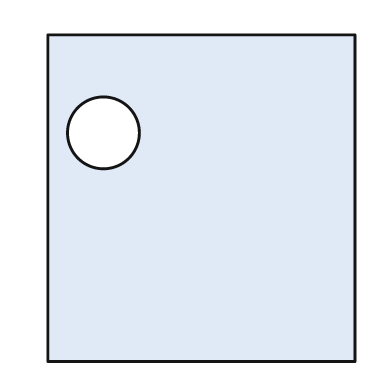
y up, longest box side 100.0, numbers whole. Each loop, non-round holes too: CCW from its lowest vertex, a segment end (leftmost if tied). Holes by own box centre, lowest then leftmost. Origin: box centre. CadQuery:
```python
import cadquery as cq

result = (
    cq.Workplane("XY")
    .moveTo(-47.0, -50.0)
    .lineTo(47.0, -50.0)
    .lineTo(47.0, 50.0)
    .lineTo(-47.0, 50.0)
    .close()
    .moveTo(-30.0, 20.0)
    .circle(11.0)
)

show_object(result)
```